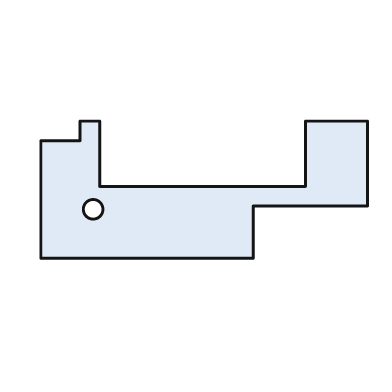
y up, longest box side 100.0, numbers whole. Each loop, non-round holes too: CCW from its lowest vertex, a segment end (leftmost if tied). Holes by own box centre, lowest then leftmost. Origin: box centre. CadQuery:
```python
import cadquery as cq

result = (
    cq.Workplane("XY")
    .moveTo(-50.0, -21.0)
    .lineTo(15.0, -21.0)
    .lineTo(15.0, -5.0)
    .lineTo(50.0, -5.0)
    .lineTo(50.0, 21.0)
    .lineTo(31.0, 21.0)
    .lineTo(31.0, 1.0)
    .lineTo(-32.0, 1.0)
    .lineTo(-32.0, 21.0)
    .lineTo(-38.0, 21.0)
    .lineTo(-38.0, 15.0)
    .lineTo(-50.0, 15.0)
    .close()
    .moveTo(-34.0, -6.0)
    .circle(3.0)
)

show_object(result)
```